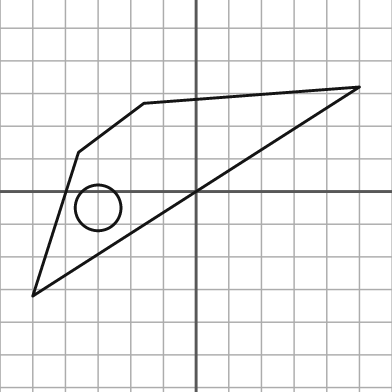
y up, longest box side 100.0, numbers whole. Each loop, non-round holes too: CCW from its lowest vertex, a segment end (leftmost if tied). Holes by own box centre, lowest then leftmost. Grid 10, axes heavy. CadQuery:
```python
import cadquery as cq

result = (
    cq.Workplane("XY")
    .moveTo(-50.0, -32.0)
    .lineTo(50.0, 32.0)
    .lineTo(-16.0, 27.0)
    .lineTo(-36.0, 12.0)
    .close()
    .moveTo(-30.0, -5.0)
    .circle(7.0)
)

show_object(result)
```